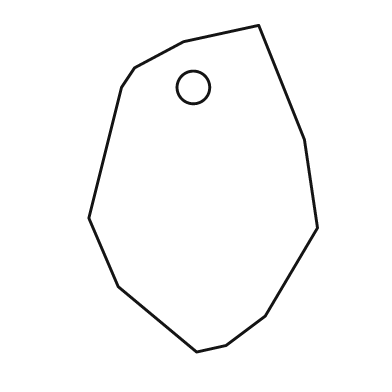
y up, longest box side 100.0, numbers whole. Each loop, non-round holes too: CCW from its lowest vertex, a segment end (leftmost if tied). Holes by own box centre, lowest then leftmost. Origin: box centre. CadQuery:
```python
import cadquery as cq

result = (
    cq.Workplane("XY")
    .moveTo(-2.0, -50.0)
    .lineTo(7.0, -48.0)
    .lineTo(19.0, -39.0)
    .lineTo(35.0, -12.0)
    .lineTo(31.0, 15.0)
    .lineTo(17.0, 50.0)
    .lineTo(-6.0, 45.0)
    .lineTo(-21.0, 37.0)
    .lineTo(-25.0, 31.0)
    .lineTo(-35.0, -9.0)
    .lineTo(-26.0, -30.0)
    .close()
    .moveTo(-3.0, 31.0)
    .circle(5.0)
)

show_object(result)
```